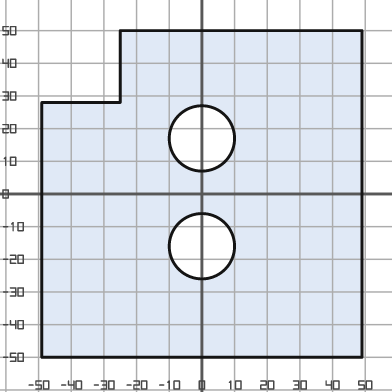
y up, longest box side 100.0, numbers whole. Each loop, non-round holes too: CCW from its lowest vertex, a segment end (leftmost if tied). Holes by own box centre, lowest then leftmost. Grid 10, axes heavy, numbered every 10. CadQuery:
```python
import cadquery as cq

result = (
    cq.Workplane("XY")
    .moveTo(-49.0, -50.0)
    .lineTo(49.0, -50.0)
    .lineTo(49.0, 50.0)
    .lineTo(-25.0, 50.0)
    .lineTo(-25.0, 28.0)
    .lineTo(-49.0, 28.0)
    .close()
    .moveTo(0.0, -16.0)
    .circle(10.0)
    .moveTo(0.0, 17.0)
    .circle(10.0)
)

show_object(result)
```